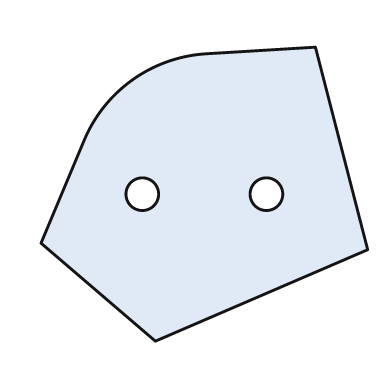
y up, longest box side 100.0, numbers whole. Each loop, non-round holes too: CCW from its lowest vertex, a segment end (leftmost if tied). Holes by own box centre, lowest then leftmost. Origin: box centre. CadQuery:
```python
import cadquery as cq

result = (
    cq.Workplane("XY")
    .moveTo(-15.0, -45.0)
    .lineTo(50.0, -17.0)
    .lineTo(34.0, 45.0)
    .lineTo(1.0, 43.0)
    .threePointArc((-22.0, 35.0), (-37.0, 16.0))
    .lineTo(-50.0, -15.0)
    .close()
    .moveTo(-19.0, 0.0)
    .circle(5.0)
    .moveTo(19.0, 0.0)
    .circle(5.0)
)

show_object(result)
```